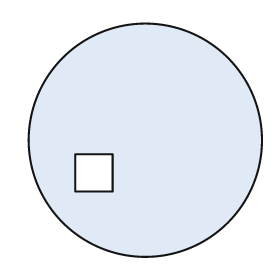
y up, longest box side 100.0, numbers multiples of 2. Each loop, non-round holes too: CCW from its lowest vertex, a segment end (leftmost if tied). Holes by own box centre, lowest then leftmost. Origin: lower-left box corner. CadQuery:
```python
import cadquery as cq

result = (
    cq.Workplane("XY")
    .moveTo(50.0, 50.0)
    .circle(50.0)
    .moveTo(20.0, 28.0)
    .lineTo(36.0, 28.0)
    .lineTo(36.0, 44.0)
    .lineTo(20.0, 44.0)
    .close()
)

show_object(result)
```